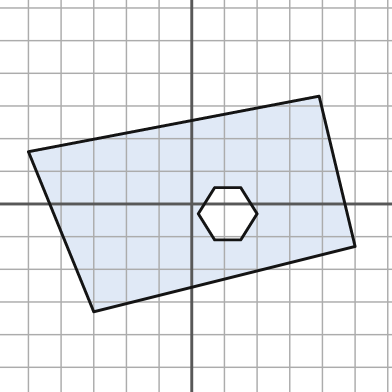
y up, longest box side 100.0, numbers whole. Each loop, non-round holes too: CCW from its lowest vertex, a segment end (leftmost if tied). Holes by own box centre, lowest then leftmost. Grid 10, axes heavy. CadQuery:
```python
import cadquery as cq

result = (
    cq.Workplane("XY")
    .moveTo(-30.0, -33.0)
    .lineTo(50.0, -13.0)
    .lineTo(39.0, 33.0)
    .lineTo(-50.0, 16.0)
    .close()
    .moveTo(7.0, -11.0)
    .lineTo(15.0, -11.0)
    .lineTo(20.0, -3.0)
    .lineTo(15.0, 5.0)
    .lineTo(7.0, 5.0)
    .lineTo(2.0, -3.0)
    .close()
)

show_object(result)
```